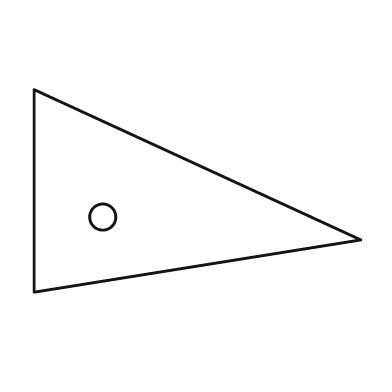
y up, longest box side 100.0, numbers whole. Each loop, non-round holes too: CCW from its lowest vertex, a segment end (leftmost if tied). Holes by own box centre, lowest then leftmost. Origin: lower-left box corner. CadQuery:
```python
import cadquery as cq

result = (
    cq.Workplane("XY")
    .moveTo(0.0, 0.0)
    .lineTo(100.0, 16.0)
    .lineTo(0.0, 62.0)
    .close()
    .moveTo(21.0, 23.0)
    .circle(4.0)
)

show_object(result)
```